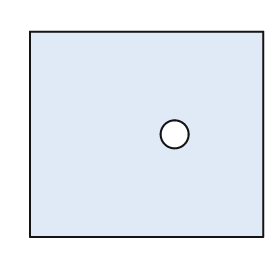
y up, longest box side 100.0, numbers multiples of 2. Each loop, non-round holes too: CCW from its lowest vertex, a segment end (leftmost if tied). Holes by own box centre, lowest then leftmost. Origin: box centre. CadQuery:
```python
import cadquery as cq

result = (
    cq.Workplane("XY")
    .moveTo(-50.0, -44.0)
    .lineTo(50.0, -44.0)
    .lineTo(50.0, 44.0)
    .lineTo(-50.0, 44.0)
    .close()
    .moveTo(12.0, 0.0)
    .circle(6.0)
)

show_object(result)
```